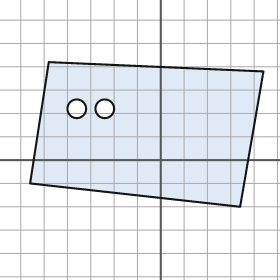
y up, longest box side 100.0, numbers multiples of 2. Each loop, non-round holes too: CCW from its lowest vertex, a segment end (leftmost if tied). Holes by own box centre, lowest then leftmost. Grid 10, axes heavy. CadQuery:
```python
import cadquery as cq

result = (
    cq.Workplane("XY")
    .moveTo(34.0, -20.0)
    .lineTo(44.0, 38.0)
    .lineTo(-48.0, 42.0)
    .lineTo(-56.0, -10.0)
    .close()
    .moveTo(-36.0, 22.0)
    .circle(4.0)
    .moveTo(-24.0, 22.0)
    .circle(4.0)
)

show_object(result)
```